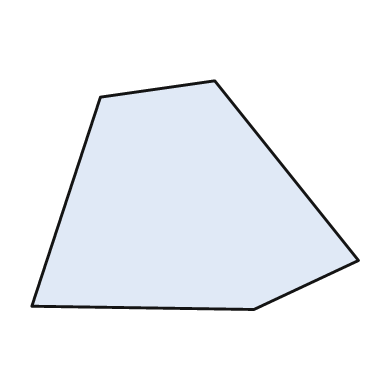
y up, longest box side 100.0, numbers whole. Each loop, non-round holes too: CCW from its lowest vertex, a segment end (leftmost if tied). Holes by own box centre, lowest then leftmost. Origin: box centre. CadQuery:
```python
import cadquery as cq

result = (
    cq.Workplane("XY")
    .moveTo(18.0, -35.0)
    .lineTo(50.0, -20.0)
    .lineTo(6.0, 35.0)
    .lineTo(-29.0, 30.0)
    .lineTo(-50.0, -34.0)
    .close()
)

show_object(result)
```